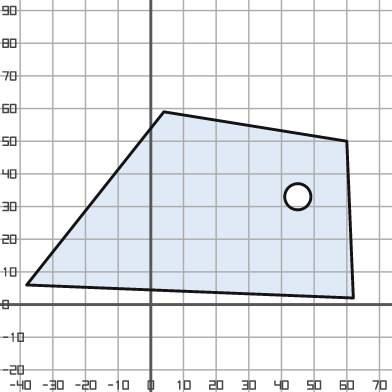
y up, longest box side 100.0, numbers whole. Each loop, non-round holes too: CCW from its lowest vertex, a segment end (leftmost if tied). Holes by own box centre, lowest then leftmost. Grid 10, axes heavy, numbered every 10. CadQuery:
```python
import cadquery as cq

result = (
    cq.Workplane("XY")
    .moveTo(62.0, 2.0)
    .lineTo(60.0, 50.0)
    .lineTo(4.0, 59.0)
    .lineTo(-38.0, 6.0)
    .close()
    .moveTo(45.0, 33.0)
    .circle(4.0)
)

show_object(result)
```